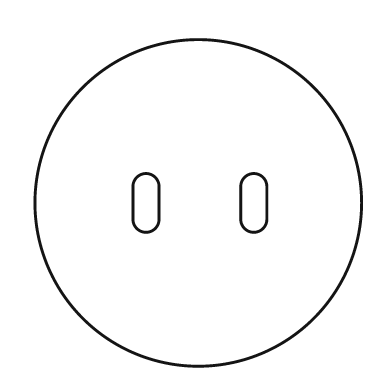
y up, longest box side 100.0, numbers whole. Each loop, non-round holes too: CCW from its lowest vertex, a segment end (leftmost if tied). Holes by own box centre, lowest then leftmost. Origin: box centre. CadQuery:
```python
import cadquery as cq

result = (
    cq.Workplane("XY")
    .moveTo(0.0, 0.0)
    .circle(50.0)
    .moveTo(-20.0, -5.0)
    .threePointArc((-16.0, -9.0), (-12.0, -5.0))
    .lineTo(-12.0, 5.0)
    .threePointArc((-16.0, 9.0), (-20.0, 5.0))
    .close()
    .moveTo(13.0, -5.0)
    .threePointArc((17.0, -9.0), (21.0, -5.0))
    .lineTo(21.0, 5.0)
    .threePointArc((17.0, 9.0), (13.0, 5.0))
    .close()
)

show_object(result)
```